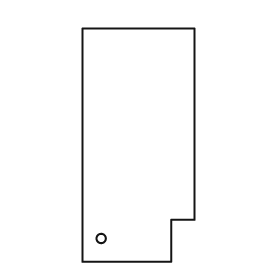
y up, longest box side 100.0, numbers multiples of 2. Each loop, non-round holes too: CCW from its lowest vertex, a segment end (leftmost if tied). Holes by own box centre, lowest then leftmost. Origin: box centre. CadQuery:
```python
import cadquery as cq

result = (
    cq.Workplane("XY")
    .moveTo(-24.0, -50.0)
    .lineTo(14.0, -50.0)
    .lineTo(14.0, -32.0)
    .lineTo(24.0, -32.0)
    .lineTo(24.0, 50.0)
    .lineTo(-24.0, 50.0)
    .close()
    .moveTo(-16.0, -40.0)
    .circle(2.0)
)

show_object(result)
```